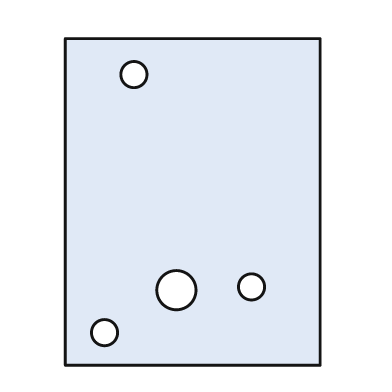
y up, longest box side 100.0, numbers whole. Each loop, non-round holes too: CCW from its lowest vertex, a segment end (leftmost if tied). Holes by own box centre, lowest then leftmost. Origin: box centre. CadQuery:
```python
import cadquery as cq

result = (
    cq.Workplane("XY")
    .moveTo(-39.0, -50.0)
    .lineTo(39.0, -50.0)
    .lineTo(39.0, 50.0)
    .lineTo(-39.0, 50.0)
    .close()
    .moveTo(-27.0, -40.0)
    .circle(4.0)
    .moveTo(-5.0, -27.0)
    .circle(6.0)
    .moveTo(18.0, -26.0)
    .circle(4.0)
    .moveTo(-18.0, 39.0)
    .circle(4.0)
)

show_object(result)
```